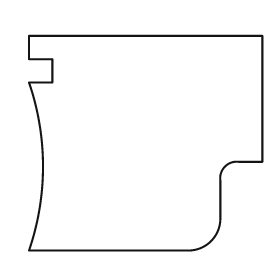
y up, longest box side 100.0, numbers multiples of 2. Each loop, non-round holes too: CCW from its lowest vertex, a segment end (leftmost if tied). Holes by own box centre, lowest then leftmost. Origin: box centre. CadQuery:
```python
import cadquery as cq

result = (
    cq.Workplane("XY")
    .moveTo(-50.0, -46.0)
    .lineTo(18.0, -46.0)
    .threePointArc((28.0, -42.0), (32.0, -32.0))
    .lineTo(32.0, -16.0)
    .threePointArc((34.0, -10.0), (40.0, -8.0))
    .lineTo(50.0, -8.0)
    .lineTo(50.0, 46.0)
    .lineTo(-50.0, 46.0)
    .lineTo(-50.0, 36.0)
    .lineTo(-40.0, 36.0)
    .lineTo(-40.0, 26.0)
    .lineTo(-50.0, 26.0)
    .threePointArc((-44.0, -10.0), (-50.0, -46.0))
    .close()
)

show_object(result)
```